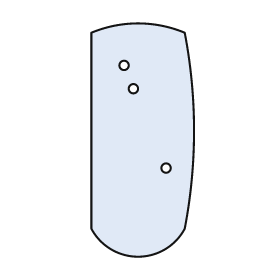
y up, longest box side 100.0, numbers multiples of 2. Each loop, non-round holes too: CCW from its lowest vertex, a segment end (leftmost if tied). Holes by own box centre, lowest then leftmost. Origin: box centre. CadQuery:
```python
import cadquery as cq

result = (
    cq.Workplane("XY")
    .moveTo(-22.0, -38.0)
    .threePointArc((-2.0, -50.0), (18.0, -38.0))
    .threePointArc((22.0, 4.0), (18.0, 46.0))
    .threePointArc((-2.0, 50.0), (-22.0, 46.0))
    .close()
    .moveTo(10.0, -12.0)
    .circle(2.0)
    .moveTo(-4.0, 22.0)
    .circle(2.0)
    .moveTo(-8.0, 32.0)
    .circle(2.0)
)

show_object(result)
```